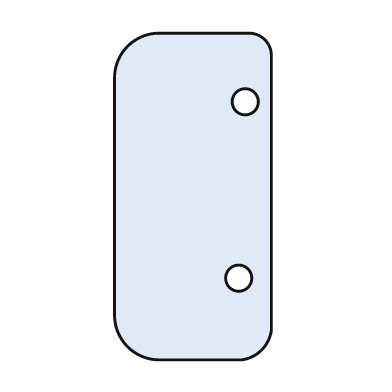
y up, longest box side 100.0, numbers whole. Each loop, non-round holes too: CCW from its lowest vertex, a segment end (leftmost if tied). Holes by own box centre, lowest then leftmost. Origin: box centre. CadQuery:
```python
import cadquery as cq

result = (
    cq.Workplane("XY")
    .moveTo(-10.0, -50.0)
    .lineTo(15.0, -50.0)
    .threePointArc((21.0, -47.0), (24.0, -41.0))
    .lineTo(24.0, 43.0)
    .threePointArc((22.0, 48.0), (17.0, 50.0))
    .lineTo(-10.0, 50.0)
    .threePointArc((-20.0, 46.0), (-24.0, 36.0))
    .lineTo(-24.0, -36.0)
    .threePointArc((-20.0, -46.0), (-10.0, -50.0))
    .close()
    .moveTo(14.0, -25.0)
    .circle(4.0)
    .moveTo(16.0, 29.0)
    .circle(4.0)
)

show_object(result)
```